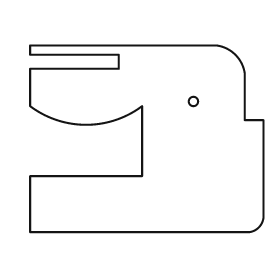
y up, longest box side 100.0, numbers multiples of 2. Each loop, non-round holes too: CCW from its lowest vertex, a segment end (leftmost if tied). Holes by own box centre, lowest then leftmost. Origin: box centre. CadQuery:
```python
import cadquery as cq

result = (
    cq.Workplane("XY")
    .moveTo(-50.0, -40.0)
    .lineTo(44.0, -40.0)
    .threePointArc((48.0, -38.0), (50.0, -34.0))
    .lineTo(50.0, 8.0)
    .lineTo(42.0, 8.0)
    .lineTo(42.0, 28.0)
    .threePointArc((38.0, 36.0), (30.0, 40.0))
    .lineTo(-50.0, 40.0)
    .lineTo(-50.0, 36.0)
    .lineTo(-12.0, 36.0)
    .lineTo(-12.0, 30.0)
    .lineTo(-50.0, 30.0)
    .lineTo(-50.0, 14.0)
    .threePointArc((-26.0, 6.0), (-2.0, 14.0))
    .lineTo(-2.0, -16.0)
    .lineTo(-50.0, -16.0)
    .close()
    .moveTo(20.0, 16.0)
    .circle(2.0)
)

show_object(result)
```